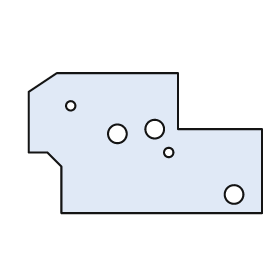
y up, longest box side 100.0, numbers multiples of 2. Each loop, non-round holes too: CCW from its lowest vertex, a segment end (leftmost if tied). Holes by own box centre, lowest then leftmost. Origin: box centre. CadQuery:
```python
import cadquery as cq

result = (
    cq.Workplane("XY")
    .moveTo(-36.0, -30.0)
    .lineTo(50.0, -30.0)
    .lineTo(50.0, 6.0)
    .lineTo(14.0, 6.0)
    .lineTo(14.0, 30.0)
    .lineTo(-38.0, 30.0)
    .lineTo(-50.0, 22.0)
    .lineTo(-50.0, -4.0)
    .lineTo(-42.0, -4.0)
    .lineTo(-36.0, -10.0)
    .close()
    .moveTo(38.0, -22.0)
    .circle(4.0)
    .moveTo(10.0, -4.0)
    .circle(2.0)
    .moveTo(-12.0, 4.0)
    .circle(4.0)
    .moveTo(4.0, 6.0)
    .circle(4.0)
    .moveTo(-32.0, 16.0)
    .circle(2.0)
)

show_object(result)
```